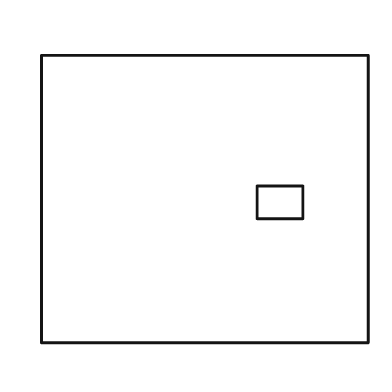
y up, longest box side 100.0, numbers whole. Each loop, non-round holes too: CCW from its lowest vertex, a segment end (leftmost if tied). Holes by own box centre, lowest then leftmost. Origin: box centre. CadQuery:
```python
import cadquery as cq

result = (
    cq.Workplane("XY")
    .moveTo(-50.0, -44.0)
    .lineTo(50.0, -44.0)
    .lineTo(50.0, 44.0)
    .lineTo(-50.0, 44.0)
    .close()
    .moveTo(16.0, -6.0)
    .lineTo(30.0, -6.0)
    .lineTo(30.0, 4.0)
    .lineTo(16.0, 4.0)
    .close()
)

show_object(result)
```